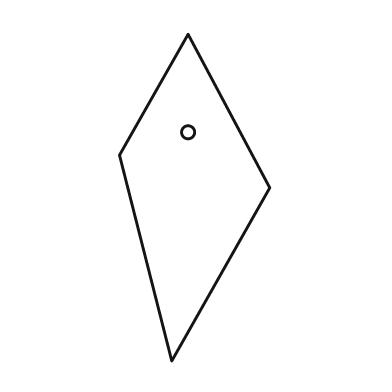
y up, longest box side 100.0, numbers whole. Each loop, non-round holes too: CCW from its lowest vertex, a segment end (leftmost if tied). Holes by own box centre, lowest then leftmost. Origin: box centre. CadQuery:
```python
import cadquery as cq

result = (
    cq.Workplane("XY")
    .moveTo(-7.0, -50.0)
    .lineTo(23.0, 3.0)
    .lineTo(-2.0, 50.0)
    .lineTo(-23.0, 13.0)
    .close()
    .moveTo(-2.0, 20.0)
    .circle(2.0)
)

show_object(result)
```